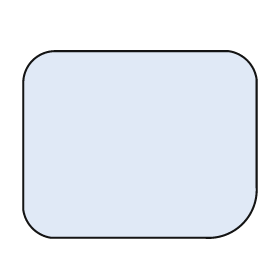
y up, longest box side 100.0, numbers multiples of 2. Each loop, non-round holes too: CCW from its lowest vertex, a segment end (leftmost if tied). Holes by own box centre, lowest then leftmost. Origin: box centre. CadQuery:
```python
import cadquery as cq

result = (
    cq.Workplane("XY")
    .moveTo(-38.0, -40.0)
    .lineTo(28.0, -40.0)
    .threePointArc((44.0, -34.0), (50.0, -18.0))
    .lineTo(50.0, 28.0)
    .threePointArc((46.0, 36.0), (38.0, 40.0))
    .lineTo(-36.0, 40.0)
    .threePointArc((-46.0, 36.0), (-50.0, 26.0))
    .lineTo(-50.0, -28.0)
    .threePointArc((-46.0, -36.0), (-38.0, -40.0))
    .close()
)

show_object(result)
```